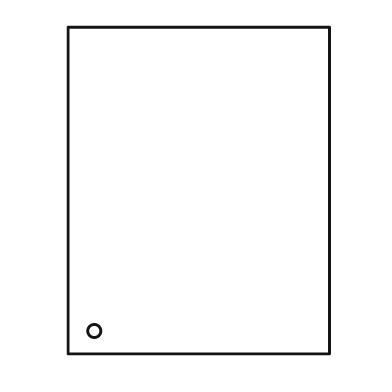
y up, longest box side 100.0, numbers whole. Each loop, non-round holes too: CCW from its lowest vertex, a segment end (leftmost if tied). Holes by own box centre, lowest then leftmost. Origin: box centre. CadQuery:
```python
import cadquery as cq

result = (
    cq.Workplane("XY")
    .moveTo(-40.0, -50.0)
    .lineTo(40.0, -50.0)
    .lineTo(40.0, 50.0)
    .lineTo(-40.0, 50.0)
    .close()
    .moveTo(-32.0, -43.0)
    .circle(2.0)
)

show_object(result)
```